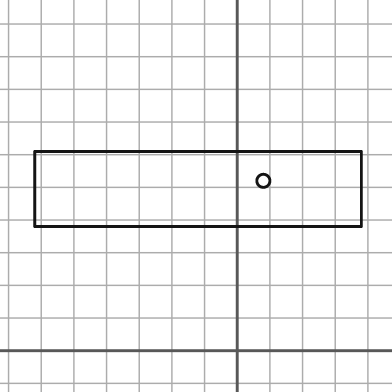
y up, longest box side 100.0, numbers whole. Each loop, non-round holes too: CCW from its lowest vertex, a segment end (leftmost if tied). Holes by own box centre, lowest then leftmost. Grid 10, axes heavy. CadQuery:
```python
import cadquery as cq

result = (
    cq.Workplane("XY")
    .moveTo(-62.0, 38.0)
    .lineTo(38.0, 38.0)
    .lineTo(38.0, 61.0)
    .lineTo(-62.0, 61.0)
    .close()
    .moveTo(8.0, 52.0)
    .circle(2.0)
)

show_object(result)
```